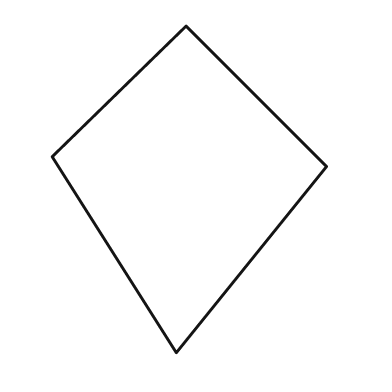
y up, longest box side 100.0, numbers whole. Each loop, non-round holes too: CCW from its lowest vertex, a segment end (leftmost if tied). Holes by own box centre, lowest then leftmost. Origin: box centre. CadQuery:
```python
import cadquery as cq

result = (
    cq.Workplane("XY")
    .moveTo(-4.0, -50.0)
    .lineTo(42.0, 7.0)
    .lineTo(-1.0, 50.0)
    .lineTo(-42.0, 10.0)
    .close()
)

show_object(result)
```